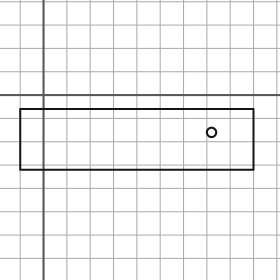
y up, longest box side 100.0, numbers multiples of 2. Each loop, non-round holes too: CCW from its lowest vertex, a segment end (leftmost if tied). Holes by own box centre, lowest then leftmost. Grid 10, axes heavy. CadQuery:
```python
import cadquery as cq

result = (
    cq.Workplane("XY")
    .moveTo(-10.0, -32.0)
    .lineTo(90.0, -32.0)
    .lineTo(90.0, -6.0)
    .lineTo(-10.0, -6.0)
    .close()
    .moveTo(72.0, -16.0)
    .circle(2.0)
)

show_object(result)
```